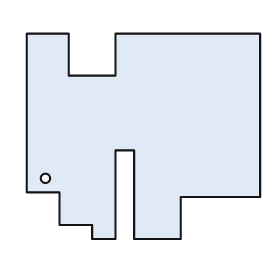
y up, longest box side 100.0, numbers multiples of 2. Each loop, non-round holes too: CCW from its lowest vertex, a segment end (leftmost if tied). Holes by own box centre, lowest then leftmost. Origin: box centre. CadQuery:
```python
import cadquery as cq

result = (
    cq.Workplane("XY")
    .moveTo(-22.0, -44.0)
    .lineTo(-12.0, -44.0)
    .lineTo(-12.0, -6.0)
    .lineTo(-4.0, -6.0)
    .lineTo(-4.0, -44.0)
    .lineTo(16.0, -44.0)
    .lineTo(16.0, -26.0)
    .lineTo(50.0, -26.0)
    .lineTo(50.0, 44.0)
    .lineTo(-12.0, 44.0)
    .lineTo(-12.0, 26.0)
    .lineTo(-32.0, 26.0)
    .lineTo(-32.0, 44.0)
    .lineTo(-50.0, 44.0)
    .lineTo(-50.0, -24.0)
    .lineTo(-36.0, -24.0)
    .lineTo(-36.0, -38.0)
    .lineTo(-22.0, -38.0)
    .close()
    .moveTo(-42.0, -18.0)
    .circle(2.0)
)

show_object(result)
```